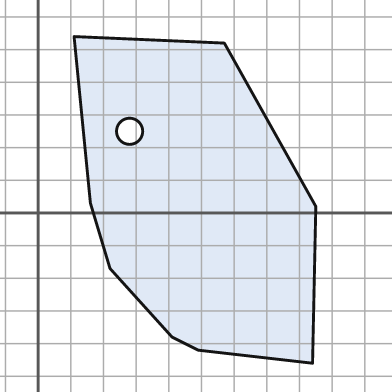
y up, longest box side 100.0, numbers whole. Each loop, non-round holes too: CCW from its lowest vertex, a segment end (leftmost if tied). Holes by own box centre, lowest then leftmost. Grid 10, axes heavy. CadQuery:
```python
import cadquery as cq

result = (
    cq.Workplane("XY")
    .moveTo(84.0, -46.0)
    .lineTo(85.0, 2.0)
    .lineTo(57.0, 52.0)
    .lineTo(11.0, 54.0)
    .lineTo(16.0, 3.0)
    .lineTo(22.0, -17.0)
    .lineTo(41.0, -38.0)
    .lineTo(49.0, -42.0)
    .close()
    .moveTo(28.0, 25.0)
    .circle(4.0)
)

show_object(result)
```